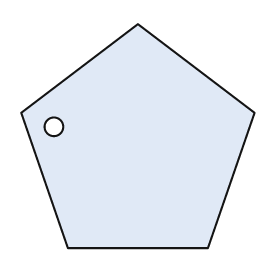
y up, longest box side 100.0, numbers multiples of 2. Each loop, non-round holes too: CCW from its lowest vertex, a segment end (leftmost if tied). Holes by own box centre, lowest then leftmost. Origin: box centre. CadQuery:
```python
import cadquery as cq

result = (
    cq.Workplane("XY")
    .moveTo(-30.0, -48.0)
    .lineTo(30.0, -48.0)
    .lineTo(50.0, 10.0)
    .lineTo(0.0, 48.0)
    .lineTo(-50.0, 10.0)
    .close()
    .moveTo(-36.0, 4.0)
    .circle(4.0)
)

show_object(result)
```